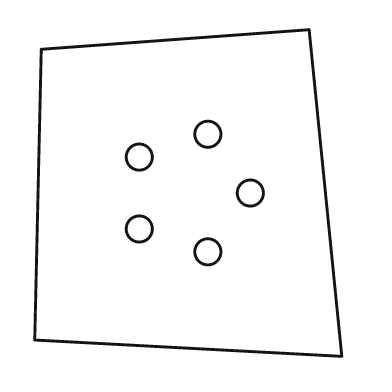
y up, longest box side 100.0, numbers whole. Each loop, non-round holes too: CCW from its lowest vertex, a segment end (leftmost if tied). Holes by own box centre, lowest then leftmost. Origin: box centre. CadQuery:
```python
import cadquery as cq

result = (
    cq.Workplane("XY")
    .moveTo(47.0, -50.0)
    .lineTo(37.0, 50.0)
    .lineTo(-45.0, 44.0)
    .lineTo(-47.0, -45.0)
    .close()
    .moveTo(6.0, -18.0)
    .circle(4.0)
    .moveTo(-15.0, -11.0)
    .circle(4.0)
    .moveTo(19.0, 0.0)
    .circle(4.0)
    .moveTo(-15.0, 11.0)
    .circle(4.0)
    .moveTo(6.0, 18.0)
    .circle(4.0)
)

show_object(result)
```